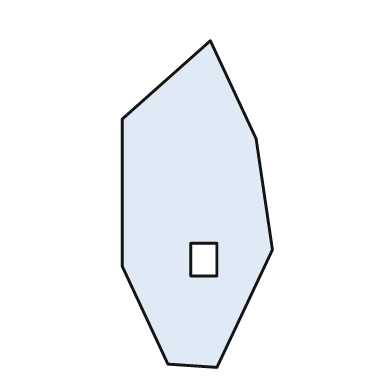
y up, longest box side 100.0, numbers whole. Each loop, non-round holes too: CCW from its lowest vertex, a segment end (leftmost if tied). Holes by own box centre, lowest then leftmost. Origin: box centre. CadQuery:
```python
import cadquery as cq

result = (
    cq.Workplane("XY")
    .moveTo(6.0, -50.0)
    .lineTo(23.0, -14.0)
    .lineTo(18.0, 20.0)
    .lineTo(4.0, 50.0)
    .lineTo(-23.0, 26.0)
    .lineTo(-23.0, -19.0)
    .lineTo(-9.0, -49.0)
    .close()
    .moveTo(-2.0, -22.0)
    .lineTo(6.0, -22.0)
    .lineTo(6.0, -12.0)
    .lineTo(-2.0, -12.0)
    .close()
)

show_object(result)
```